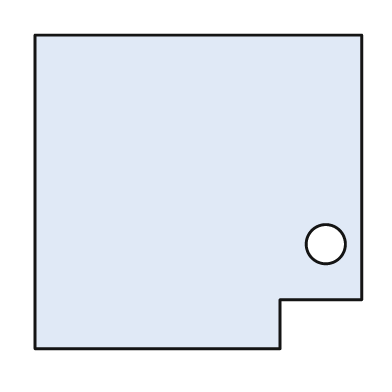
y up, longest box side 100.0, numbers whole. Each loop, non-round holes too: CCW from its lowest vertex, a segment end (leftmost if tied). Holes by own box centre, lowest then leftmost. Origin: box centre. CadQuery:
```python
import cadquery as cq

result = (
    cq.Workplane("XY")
    .moveTo(-50.0, -48.0)
    .lineTo(25.0, -48.0)
    .lineTo(25.0, -33.0)
    .lineTo(50.0, -33.0)
    .lineTo(50.0, 48.0)
    .lineTo(-50.0, 48.0)
    .close()
    .moveTo(39.0, -16.0)
    .circle(6.0)
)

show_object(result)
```